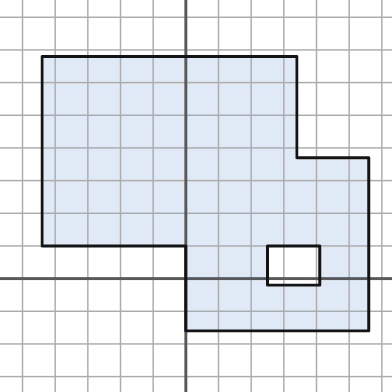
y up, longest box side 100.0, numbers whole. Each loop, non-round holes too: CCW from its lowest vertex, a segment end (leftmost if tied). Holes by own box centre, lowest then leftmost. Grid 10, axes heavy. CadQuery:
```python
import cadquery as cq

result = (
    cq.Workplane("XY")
    .moveTo(0.0, -16.0)
    .lineTo(56.0, -16.0)
    .lineTo(56.0, 37.0)
    .lineTo(34.0, 37.0)
    .lineTo(34.0, 68.0)
    .lineTo(-44.0, 68.0)
    .lineTo(-44.0, 10.0)
    .lineTo(0.0, 10.0)
    .close()
    .moveTo(25.0, -2.0)
    .lineTo(41.0, -2.0)
    .lineTo(41.0, 10.0)
    .lineTo(25.0, 10.0)
    .close()
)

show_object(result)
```